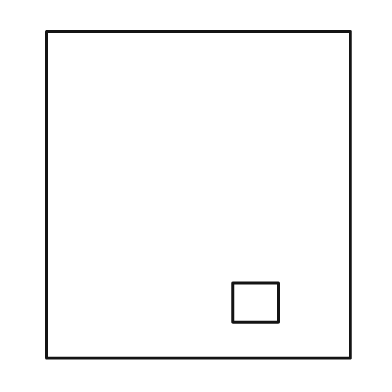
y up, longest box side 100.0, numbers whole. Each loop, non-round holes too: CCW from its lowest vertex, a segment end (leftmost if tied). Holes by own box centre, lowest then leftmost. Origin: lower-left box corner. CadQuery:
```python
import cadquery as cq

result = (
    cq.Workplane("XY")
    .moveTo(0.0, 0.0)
    .lineTo(93.0, 0.0)
    .lineTo(93.0, 100.0)
    .lineTo(0.0, 100.0)
    .close()
    .moveTo(57.0, 11.0)
    .lineTo(71.0, 11.0)
    .lineTo(71.0, 23.0)
    .lineTo(57.0, 23.0)
    .close()
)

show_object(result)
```